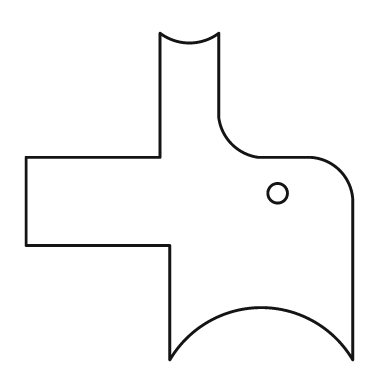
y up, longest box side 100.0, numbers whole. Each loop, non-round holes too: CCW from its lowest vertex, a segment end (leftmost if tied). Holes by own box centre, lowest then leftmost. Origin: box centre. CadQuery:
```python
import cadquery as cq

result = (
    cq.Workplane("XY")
    .moveTo(-6.0, -50.0)
    .threePointArc((22.0, -34.0), (50.0, -50.0))
    .lineTo(50.0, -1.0)
    .threePointArc((46.0, 8.0), (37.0, 12.0))
    .lineTo(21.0, 12.0)
    .threePointArc((13.0, 16.0), (9.0, 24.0))
    .lineTo(9.0, 50.0)
    .threePointArc((0.0, 47.0), (-9.0, 50.0))
    .lineTo(-9.0, 12.0)
    .lineTo(-50.0, 12.0)
    .lineTo(-50.0, -15.0)
    .lineTo(-6.0, -15.0)
    .close()
    .moveTo(27.0, 1.0)
    .circle(3.0)
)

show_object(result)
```